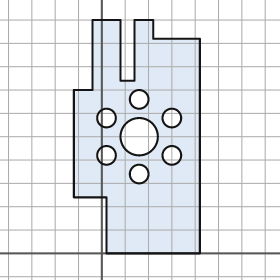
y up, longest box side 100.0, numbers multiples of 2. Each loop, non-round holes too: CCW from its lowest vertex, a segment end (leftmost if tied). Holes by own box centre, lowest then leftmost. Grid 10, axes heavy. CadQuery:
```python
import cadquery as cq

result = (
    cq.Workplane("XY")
    .moveTo(2.0, 0.0)
    .lineTo(42.0, 0.0)
    .lineTo(42.0, 92.0)
    .lineTo(22.0, 92.0)
    .lineTo(22.0, 100.0)
    .lineTo(14.0, 100.0)
    .lineTo(14.0, 74.0)
    .lineTo(8.0, 74.0)
    .lineTo(8.0, 100.0)
    .lineTo(-4.0, 100.0)
    .lineTo(-4.0, 70.0)
    .lineTo(-12.0, 70.0)
    .lineTo(-12.0, 24.0)
    .lineTo(2.0, 24.0)
    .close()
    .moveTo(16.0, 34.0)
    .circle(4.0)
    .moveTo(2.0, 42.0)
    .circle(4.0)
    .moveTo(30.0, 42.0)
    .circle(4.0)
    .moveTo(16.0, 50.0)
    .circle(8.0)
    .moveTo(2.0, 58.0)
    .circle(4.0)
    .moveTo(30.0, 58.0)
    .circle(4.0)
    .moveTo(16.0, 66.0)
    .circle(4.0)
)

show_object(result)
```